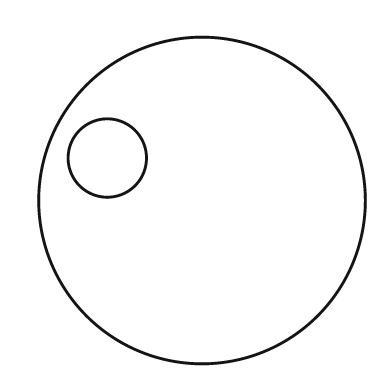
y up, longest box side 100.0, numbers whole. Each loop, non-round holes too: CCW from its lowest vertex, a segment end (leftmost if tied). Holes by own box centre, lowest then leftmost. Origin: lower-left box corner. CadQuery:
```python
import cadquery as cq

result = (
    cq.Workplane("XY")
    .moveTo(50.0, 50.0)
    .circle(50.0)
    .moveTo(21.0, 63.0)
    .circle(12.0)
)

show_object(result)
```